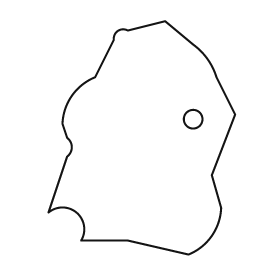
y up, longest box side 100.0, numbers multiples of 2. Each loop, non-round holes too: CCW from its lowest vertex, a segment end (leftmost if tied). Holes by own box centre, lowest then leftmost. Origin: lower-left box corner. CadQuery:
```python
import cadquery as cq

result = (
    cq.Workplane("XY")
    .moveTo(60.0, 0.0)
    .threePointArc((70.0, 8.0), (74.0, 20.0))
    .lineTo(70.0, 34.0)
    .lineTo(80.0, 60.0)
    .lineTo(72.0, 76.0)
    .threePointArc((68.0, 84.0), (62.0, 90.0))
    .lineTo(50.0, 100.0)
    .lineTo(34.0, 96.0)
    .threePointArc((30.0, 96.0), (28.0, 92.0))
    .lineTo(20.0, 76.0)
    .threePointArc((10.0, 68.0), (6.0, 56.0))
    .lineTo(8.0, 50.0)
    .threePointArc((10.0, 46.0), (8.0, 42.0))
    .lineTo(0.0, 18.0)
    .threePointArc((12.0, 18.0), (14.0, 6.0))
    .lineTo(34.0, 6.0)
    .close()
    .moveTo(62.0, 58.0)
    .circle(4.0)
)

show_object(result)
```